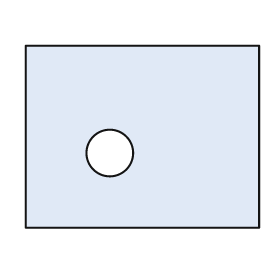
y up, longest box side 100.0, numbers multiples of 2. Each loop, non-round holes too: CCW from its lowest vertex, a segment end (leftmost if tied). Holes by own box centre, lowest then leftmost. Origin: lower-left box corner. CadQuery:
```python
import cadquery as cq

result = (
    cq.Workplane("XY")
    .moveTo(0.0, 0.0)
    .lineTo(100.0, 0.0)
    .lineTo(100.0, 78.0)
    .lineTo(0.0, 78.0)
    .close()
    .moveTo(36.0, 32.0)
    .circle(10.0)
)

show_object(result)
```